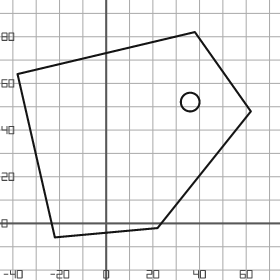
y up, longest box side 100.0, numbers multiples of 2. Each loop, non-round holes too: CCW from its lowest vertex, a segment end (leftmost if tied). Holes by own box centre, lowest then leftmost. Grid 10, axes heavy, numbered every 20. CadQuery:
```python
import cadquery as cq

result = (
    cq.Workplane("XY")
    .moveTo(-22.0, -6.0)
    .lineTo(22.0, -2.0)
    .lineTo(62.0, 48.0)
    .lineTo(38.0, 82.0)
    .lineTo(-38.0, 64.0)
    .close()
    .moveTo(36.0, 52.0)
    .circle(4.0)
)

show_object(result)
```